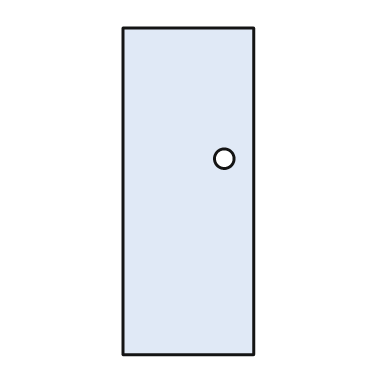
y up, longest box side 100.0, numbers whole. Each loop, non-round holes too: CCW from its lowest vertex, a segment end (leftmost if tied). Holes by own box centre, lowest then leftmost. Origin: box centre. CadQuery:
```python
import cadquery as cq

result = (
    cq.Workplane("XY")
    .moveTo(-20.0, -50.0)
    .lineTo(20.0, -50.0)
    .lineTo(20.0, 50.0)
    .lineTo(-20.0, 50.0)
    .close()
    .moveTo(11.0, 10.0)
    .circle(3.0)
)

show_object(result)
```